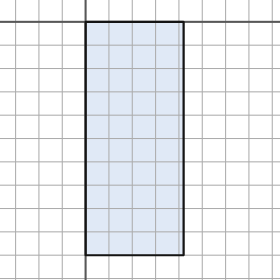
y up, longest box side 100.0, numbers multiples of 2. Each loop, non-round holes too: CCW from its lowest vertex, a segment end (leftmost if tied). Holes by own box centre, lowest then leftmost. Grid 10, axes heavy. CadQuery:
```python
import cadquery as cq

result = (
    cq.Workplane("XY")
    .moveTo(0.0, -100.0)
    .lineTo(42.0, -100.0)
    .lineTo(42.0, 0.0)
    .lineTo(0.0, 0.0)
    .close()
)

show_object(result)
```